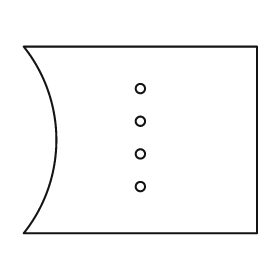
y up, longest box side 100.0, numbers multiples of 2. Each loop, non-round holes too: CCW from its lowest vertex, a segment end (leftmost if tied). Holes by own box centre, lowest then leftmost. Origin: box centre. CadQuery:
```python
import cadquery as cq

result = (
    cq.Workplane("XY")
    .moveTo(-50.0, -40.0)
    .lineTo(50.0, -40.0)
    .lineTo(50.0, 40.0)
    .lineTo(-50.0, 40.0)
    .threePointArc((-36.0, 0.0), (-50.0, -40.0))
    .close()
    .moveTo(0.0, -20.0)
    .circle(2.0)
    .moveTo(0.0, -6.0)
    .circle(2.0)
    .moveTo(0.0, 8.0)
    .circle(2.0)
    .moveTo(0.0, 22.0)
    .circle(2.0)
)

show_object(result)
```